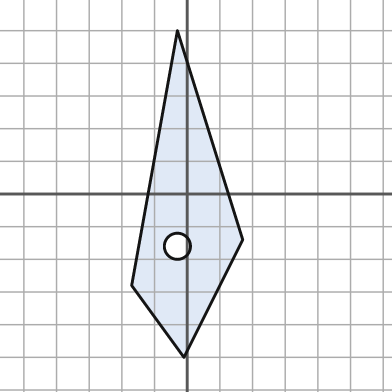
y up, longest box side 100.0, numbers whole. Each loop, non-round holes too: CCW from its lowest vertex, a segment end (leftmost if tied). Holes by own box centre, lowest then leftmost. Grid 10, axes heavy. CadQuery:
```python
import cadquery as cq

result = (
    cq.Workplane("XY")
    .moveTo(-1.0, -50.0)
    .lineTo(17.0, -14.0)
    .lineTo(-3.0, 50.0)
    .lineTo(-17.0, -28.0)
    .close()
    .moveTo(-3.0, -16.0)
    .circle(4.0)
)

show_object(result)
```